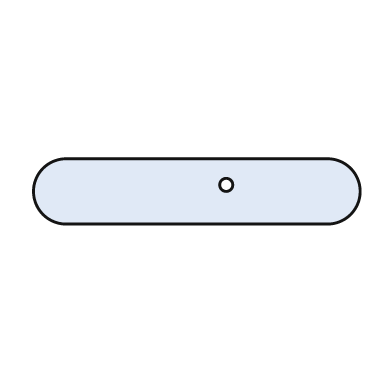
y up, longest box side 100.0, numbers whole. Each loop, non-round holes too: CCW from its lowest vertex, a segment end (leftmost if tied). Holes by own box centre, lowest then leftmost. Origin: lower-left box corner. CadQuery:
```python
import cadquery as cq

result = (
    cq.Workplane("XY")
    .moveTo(10.0, 0.0)
    .lineTo(90.0, 0.0)
    .threePointArc((100.0, 10.0), (90.0, 20.0))
    .lineTo(10.0, 20.0)
    .threePointArc((0.0, 10.0), (10.0, 0.0))
    .close()
    .moveTo(59.0, 12.0)
    .circle(2.0)
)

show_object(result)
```